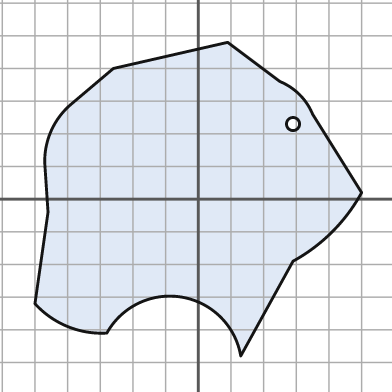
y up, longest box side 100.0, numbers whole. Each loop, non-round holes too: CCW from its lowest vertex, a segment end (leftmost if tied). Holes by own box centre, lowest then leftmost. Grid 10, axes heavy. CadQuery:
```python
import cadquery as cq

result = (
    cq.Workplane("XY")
    .moveTo(13.0, -48.0)
    .lineTo(29.0, -19.0)
    .threePointArc((41.0, -10.0), (50.0, 2.0))
    .lineTo(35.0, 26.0)
    .threePointArc((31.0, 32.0), (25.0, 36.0))
    .lineTo(9.0, 48.0)
    .lineTo(-26.0, 40.0)
    .lineTo(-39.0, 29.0)
    .threePointArc((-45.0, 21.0), (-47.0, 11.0))
    .lineTo(-46.0, -4.0)
    .lineTo(-50.0, -32.0)
    .threePointArc((-40.0, -39.0), (-28.0, -41.0))
    .threePointArc((-5.0, -30.0), (13.0, -48.0))
    .close()
    .moveTo(29.0, 23.0)
    .circle(2.0)
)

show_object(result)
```